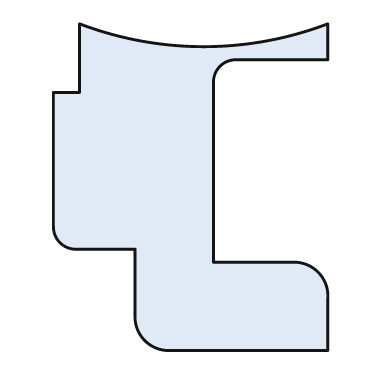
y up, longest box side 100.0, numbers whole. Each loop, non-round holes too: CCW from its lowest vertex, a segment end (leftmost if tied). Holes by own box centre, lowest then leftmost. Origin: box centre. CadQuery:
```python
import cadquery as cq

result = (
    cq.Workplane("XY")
    .moveTo(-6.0, -50.0)
    .lineTo(42.0, -50.0)
    .lineTo(42.0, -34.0)
    .threePointArc((39.0, -26.0), (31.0, -23.0))
    .lineTo(7.0, -23.0)
    .lineTo(7.0, 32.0)
    .threePointArc((9.0, 37.0), (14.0, 39.0))
    .lineTo(42.0, 39.0)
    .lineTo(42.0, 50.0)
    .threePointArc((4.0, 43.0), (-34.0, 50.0))
    .lineTo(-34.0, 29.0)
    .lineTo(-42.0, 29.0)
    .lineTo(-42.0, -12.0)
    .threePointArc((-40.0, -17.0), (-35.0, -19.0))
    .lineTo(-17.0, -19.0)
    .lineTo(-17.0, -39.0)
    .threePointArc((-14.0, -47.0), (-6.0, -50.0))
    .close()
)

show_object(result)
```